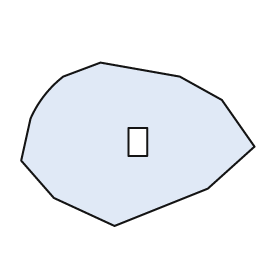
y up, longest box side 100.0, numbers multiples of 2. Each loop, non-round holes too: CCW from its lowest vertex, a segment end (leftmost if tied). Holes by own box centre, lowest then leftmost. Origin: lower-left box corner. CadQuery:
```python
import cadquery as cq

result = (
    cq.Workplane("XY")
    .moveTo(40.0, 0.0)
    .lineTo(80.0, 16.0)
    .lineTo(100.0, 34.0)
    .lineTo(86.0, 54.0)
    .lineTo(68.0, 64.0)
    .lineTo(34.0, 70.0)
    .lineTo(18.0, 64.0)
    .threePointArc((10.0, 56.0), (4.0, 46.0))
    .lineTo(0.0, 28.0)
    .lineTo(14.0, 12.0)
    .close()
    .moveTo(46.0, 30.0)
    .lineTo(54.0, 30.0)
    .lineTo(54.0, 42.0)
    .lineTo(46.0, 42.0)
    .close()
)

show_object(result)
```